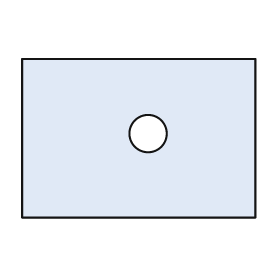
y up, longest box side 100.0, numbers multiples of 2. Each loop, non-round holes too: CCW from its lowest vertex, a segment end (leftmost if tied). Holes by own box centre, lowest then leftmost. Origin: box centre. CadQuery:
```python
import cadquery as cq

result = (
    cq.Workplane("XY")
    .moveTo(-50.0, -34.0)
    .lineTo(50.0, -34.0)
    .lineTo(50.0, 34.0)
    .lineTo(-50.0, 34.0)
    .close()
    .moveTo(4.0, 2.0)
    .circle(8.0)
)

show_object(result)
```